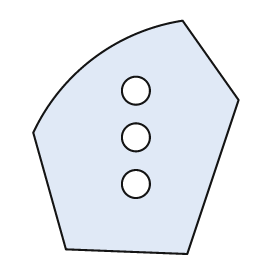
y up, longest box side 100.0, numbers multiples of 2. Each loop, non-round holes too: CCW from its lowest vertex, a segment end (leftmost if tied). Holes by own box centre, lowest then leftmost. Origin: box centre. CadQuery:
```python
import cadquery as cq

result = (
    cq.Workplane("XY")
    .moveTo(22.0, -50.0)
    .lineTo(44.0, 16.0)
    .lineTo(20.0, 50.0)
    .threePointArc((-18.0, 34.0), (-44.0, 2.0))
    .lineTo(-30.0, -48.0)
    .close()
    .moveTo(0.0, -20.0)
    .circle(6.0)
    .moveTo(0.0, 0.0)
    .circle(6.0)
    .moveTo(0.0, 20.0)
    .circle(6.0)
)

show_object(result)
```